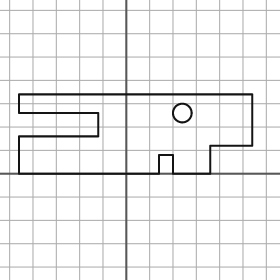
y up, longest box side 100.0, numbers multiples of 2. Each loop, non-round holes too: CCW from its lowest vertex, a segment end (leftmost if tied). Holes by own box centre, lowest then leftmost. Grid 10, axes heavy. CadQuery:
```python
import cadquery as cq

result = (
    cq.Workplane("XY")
    .moveTo(-46.0, 0.0)
    .lineTo(14.0, 0.0)
    .lineTo(14.0, 8.0)
    .lineTo(20.0, 8.0)
    .lineTo(20.0, 0.0)
    .lineTo(36.0, 0.0)
    .lineTo(36.0, 12.0)
    .lineTo(54.0, 12.0)
    .lineTo(54.0, 34.0)
    .lineTo(-46.0, 34.0)
    .lineTo(-46.0, 26.0)
    .lineTo(-12.0, 26.0)
    .lineTo(-12.0, 16.0)
    .lineTo(-46.0, 16.0)
    .close()
    .moveTo(24.0, 26.0)
    .circle(4.0)
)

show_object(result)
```